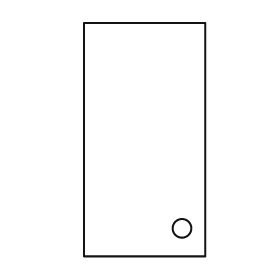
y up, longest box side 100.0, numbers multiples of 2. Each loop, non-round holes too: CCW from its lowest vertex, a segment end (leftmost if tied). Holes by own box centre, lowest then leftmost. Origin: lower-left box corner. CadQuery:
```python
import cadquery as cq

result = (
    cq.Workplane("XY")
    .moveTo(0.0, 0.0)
    .lineTo(52.0, 0.0)
    .lineTo(52.0, 100.0)
    .lineTo(0.0, 100.0)
    .close()
    .moveTo(42.0, 12.0)
    .circle(4.0)
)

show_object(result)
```